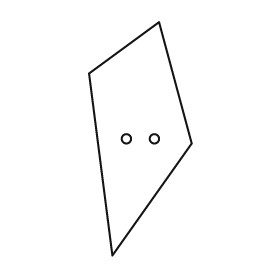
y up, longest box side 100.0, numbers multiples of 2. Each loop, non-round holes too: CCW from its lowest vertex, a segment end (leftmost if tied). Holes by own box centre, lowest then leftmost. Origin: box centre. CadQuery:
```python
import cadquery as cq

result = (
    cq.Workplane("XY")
    .moveTo(-12.0, -50.0)
    .lineTo(22.0, -2.0)
    .lineTo(8.0, 50.0)
    .lineTo(-22.0, 28.0)
    .close()
    .moveTo(-6.0, 0.0)
    .circle(2.0)
    .moveTo(6.0, 0.0)
    .circle(2.0)
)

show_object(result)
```